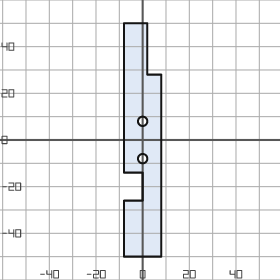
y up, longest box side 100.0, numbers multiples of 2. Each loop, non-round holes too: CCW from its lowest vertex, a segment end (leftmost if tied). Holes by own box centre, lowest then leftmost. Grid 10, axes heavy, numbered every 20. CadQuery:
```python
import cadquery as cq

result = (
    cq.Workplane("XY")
    .moveTo(-8.0, -50.0)
    .lineTo(8.0, -50.0)
    .lineTo(8.0, 28.0)
    .lineTo(2.0, 28.0)
    .lineTo(2.0, 50.0)
    .lineTo(-8.0, 50.0)
    .lineTo(-8.0, -14.0)
    .lineTo(0.0, -14.0)
    .lineTo(0.0, -26.0)
    .lineTo(-8.0, -26.0)
    .close()
    .moveTo(0.0, -8.0)
    .circle(2.0)
    .moveTo(0.0, 8.0)
    .circle(2.0)
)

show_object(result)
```